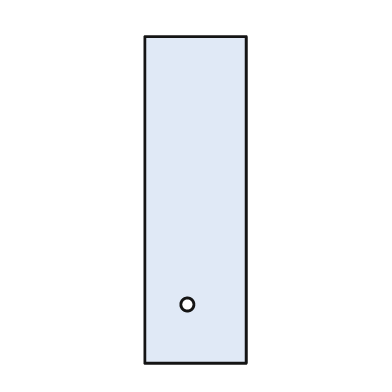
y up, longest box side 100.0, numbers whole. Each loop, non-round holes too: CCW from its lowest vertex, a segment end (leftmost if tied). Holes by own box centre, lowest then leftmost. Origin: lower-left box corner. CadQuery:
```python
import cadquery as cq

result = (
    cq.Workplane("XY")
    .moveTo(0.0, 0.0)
    .lineTo(31.0, 0.0)
    .lineTo(31.0, 100.0)
    .lineTo(0.0, 100.0)
    .close()
    .moveTo(13.0, 18.0)
    .circle(2.0)
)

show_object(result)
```